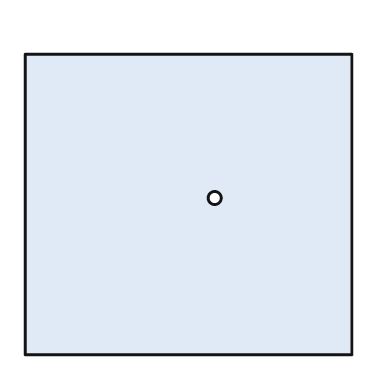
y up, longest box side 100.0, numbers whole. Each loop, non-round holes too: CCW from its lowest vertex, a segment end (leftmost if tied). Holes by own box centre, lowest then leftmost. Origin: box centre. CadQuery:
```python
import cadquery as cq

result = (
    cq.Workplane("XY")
    .moveTo(-50.0, -46.0)
    .lineTo(50.0, -46.0)
    .lineTo(50.0, 46.0)
    .lineTo(-50.0, 46.0)
    .close()
    .moveTo(8.0, 2.0)
    .circle(2.0)
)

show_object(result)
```